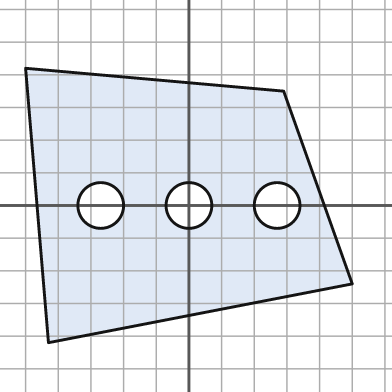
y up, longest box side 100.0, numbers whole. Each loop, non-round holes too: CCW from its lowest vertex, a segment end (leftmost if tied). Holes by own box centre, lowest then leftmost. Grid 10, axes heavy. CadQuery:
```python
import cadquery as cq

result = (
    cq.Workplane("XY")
    .moveTo(-43.0, -42.0)
    .lineTo(50.0, -24.0)
    .lineTo(29.0, 35.0)
    .lineTo(-50.0, 42.0)
    .close()
    .moveTo(-27.0, 0.0)
    .circle(7.0)
    .moveTo(0.0, 0.0)
    .circle(7.0)
    .moveTo(27.0, 0.0)
    .circle(7.0)
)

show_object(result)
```